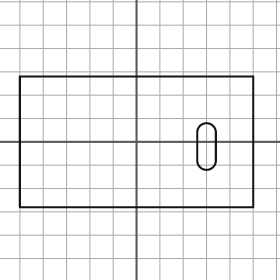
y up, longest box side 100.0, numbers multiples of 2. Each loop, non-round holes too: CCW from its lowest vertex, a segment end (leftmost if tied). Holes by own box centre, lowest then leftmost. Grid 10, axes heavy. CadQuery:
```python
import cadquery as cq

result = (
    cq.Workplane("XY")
    .moveTo(-50.0, -28.0)
    .lineTo(50.0, -28.0)
    .lineTo(50.0, 28.0)
    .lineTo(-50.0, 28.0)
    .close()
    .moveTo(26.0, -8.0)
    .threePointArc((30.0, -12.0), (34.0, -8.0))
    .lineTo(34.0, 4.0)
    .threePointArc((30.0, 8.0), (26.0, 4.0))
    .close()
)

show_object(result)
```